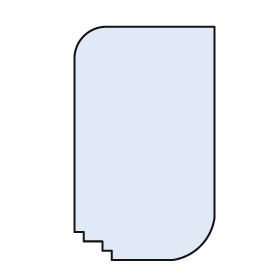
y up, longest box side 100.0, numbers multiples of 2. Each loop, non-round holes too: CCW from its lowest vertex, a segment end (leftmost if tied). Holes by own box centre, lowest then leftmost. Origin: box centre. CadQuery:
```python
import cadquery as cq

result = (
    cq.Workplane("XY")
    .moveTo(-14.0, -50.0)
    .lineTo(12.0, -50.0)
    .threePointArc((24.0, -44.0), (30.0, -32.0))
    .lineTo(30.0, 50.0)
    .lineTo(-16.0, 50.0)
    .threePointArc((-26.0, 46.0), (-30.0, 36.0))
    .lineTo(-30.0, -38.0)
    .lineTo(-26.0, -38.0)
    .lineTo(-26.0, -42.0)
    .lineTo(-18.0, -42.0)
    .lineTo(-18.0, -46.0)
    .lineTo(-14.0, -46.0)
    .close()
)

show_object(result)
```